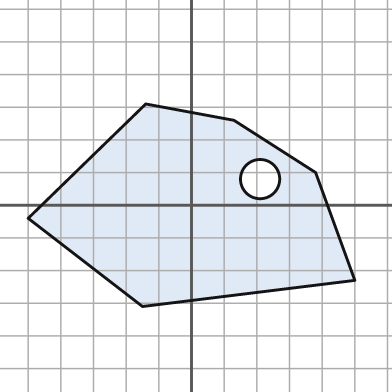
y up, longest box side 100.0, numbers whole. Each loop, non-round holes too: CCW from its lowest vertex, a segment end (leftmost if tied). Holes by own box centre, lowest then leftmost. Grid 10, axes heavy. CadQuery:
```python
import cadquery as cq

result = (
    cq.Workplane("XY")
    .moveTo(-15.0, -31.0)
    .lineTo(50.0, -23.0)
    .lineTo(38.0, 10.0)
    .lineTo(13.0, 26.0)
    .lineTo(-14.0, 31.0)
    .lineTo(-50.0, -4.0)
    .close()
    .moveTo(21.0, 8.0)
    .circle(6.0)
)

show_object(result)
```